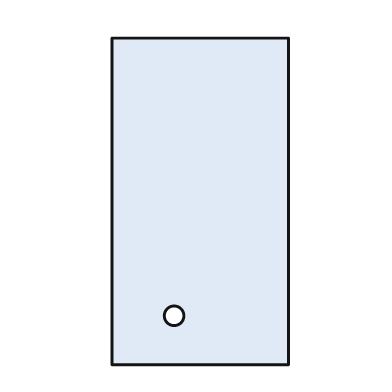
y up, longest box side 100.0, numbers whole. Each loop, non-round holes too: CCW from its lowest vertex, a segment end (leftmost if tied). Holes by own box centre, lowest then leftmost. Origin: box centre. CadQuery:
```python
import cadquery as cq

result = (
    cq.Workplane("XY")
    .moveTo(-27.0, -50.0)
    .lineTo(27.0, -50.0)
    .lineTo(27.0, 50.0)
    .lineTo(-27.0, 50.0)
    .close()
    .moveTo(-8.0, -35.0)
    .circle(3.0)
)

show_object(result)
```